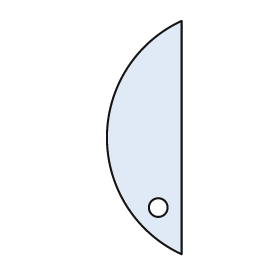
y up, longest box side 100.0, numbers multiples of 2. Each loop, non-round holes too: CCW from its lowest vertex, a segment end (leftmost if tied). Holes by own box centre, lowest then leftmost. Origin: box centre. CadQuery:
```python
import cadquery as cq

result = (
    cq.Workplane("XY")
    .moveTo(16.0, -50.0)
    .lineTo(16.0, 50.0)
    .threePointArc((-16.0, 0.0), (16.0, -50.0))
    .close()
    .moveTo(6.0, -30.0)
    .circle(4.0)
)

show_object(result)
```